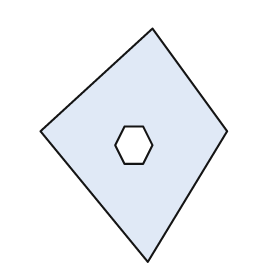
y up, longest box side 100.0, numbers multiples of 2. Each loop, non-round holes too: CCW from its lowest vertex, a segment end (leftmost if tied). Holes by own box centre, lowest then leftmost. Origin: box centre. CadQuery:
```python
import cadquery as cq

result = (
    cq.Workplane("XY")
    .moveTo(6.0, -50.0)
    .lineTo(40.0, 6.0)
    .lineTo(8.0, 50.0)
    .lineTo(-40.0, 6.0)
    .close()
    .moveTo(-4.0, -8.0)
    .lineTo(4.0, -8.0)
    .lineTo(8.0, 0.0)
    .lineTo(4.0, 8.0)
    .lineTo(-4.0, 8.0)
    .lineTo(-8.0, 0.0)
    .close()
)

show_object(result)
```